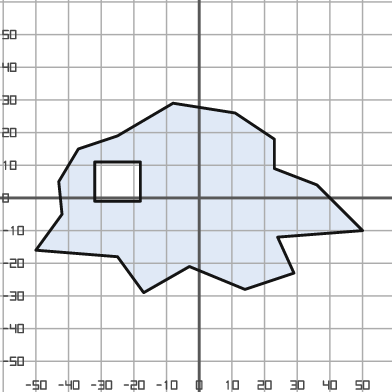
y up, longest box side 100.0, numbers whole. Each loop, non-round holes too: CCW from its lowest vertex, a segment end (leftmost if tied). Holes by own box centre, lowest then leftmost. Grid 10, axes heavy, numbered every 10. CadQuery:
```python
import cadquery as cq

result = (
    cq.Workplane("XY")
    .moveTo(-17.0, -29.0)
    .lineTo(-3.0, -21.0)
    .lineTo(14.0, -28.0)
    .lineTo(29.0, -23.0)
    .lineTo(24.0, -12.0)
    .lineTo(50.0, -10.0)
    .lineTo(36.0, 4.0)
    .lineTo(23.0, 9.0)
    .lineTo(23.0, 18.0)
    .lineTo(11.0, 26.0)
    .lineTo(-8.0, 29.0)
    .lineTo(-25.0, 19.0)
    .lineTo(-37.0, 15.0)
    .lineTo(-43.0, 5.0)
    .lineTo(-42.0, -5.0)
    .lineTo(-50.0, -16.0)
    .lineTo(-25.0, -18.0)
    .close()
    .moveTo(-32.0, -1.0)
    .lineTo(-18.0, -1.0)
    .lineTo(-18.0, 11.0)
    .lineTo(-32.0, 11.0)
    .close()
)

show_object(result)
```